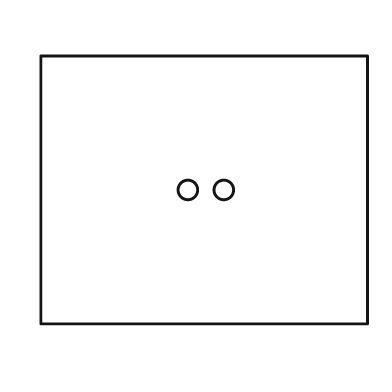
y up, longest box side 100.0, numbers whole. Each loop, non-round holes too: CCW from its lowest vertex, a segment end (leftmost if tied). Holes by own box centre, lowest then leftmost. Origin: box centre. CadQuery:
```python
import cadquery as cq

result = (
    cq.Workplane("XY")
    .moveTo(-50.0, -41.0)
    .lineTo(50.0, -41.0)
    .lineTo(50.0, 41.0)
    .lineTo(-50.0, 41.0)
    .close()
    .moveTo(-5.0, 0.0)
    .circle(3.0)
    .moveTo(6.0, 0.0)
    .circle(3.0)
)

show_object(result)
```